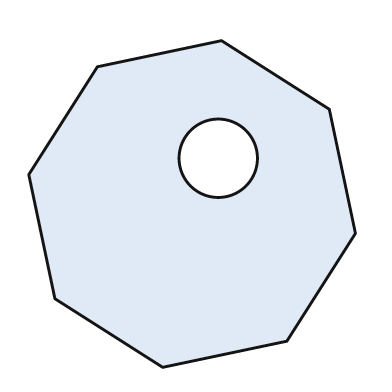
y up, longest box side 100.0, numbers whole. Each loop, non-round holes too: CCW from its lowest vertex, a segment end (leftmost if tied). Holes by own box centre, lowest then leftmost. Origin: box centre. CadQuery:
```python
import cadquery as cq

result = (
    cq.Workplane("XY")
    .moveTo(-9.0, -50.0)
    .lineTo(29.0, -42.0)
    .lineTo(50.0, -9.0)
    .lineTo(42.0, 29.0)
    .lineTo(9.0, 50.0)
    .lineTo(-29.0, 42.0)
    .lineTo(-50.0, 9.0)
    .lineTo(-42.0, -29.0)
    .close()
    .moveTo(8.0, 14.0)
    .circle(12.0)
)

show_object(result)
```